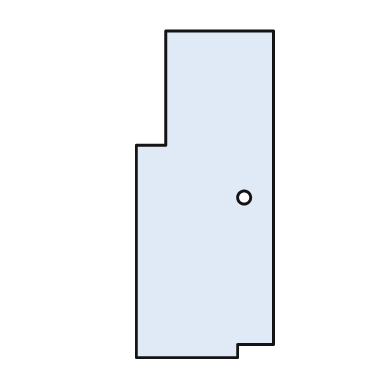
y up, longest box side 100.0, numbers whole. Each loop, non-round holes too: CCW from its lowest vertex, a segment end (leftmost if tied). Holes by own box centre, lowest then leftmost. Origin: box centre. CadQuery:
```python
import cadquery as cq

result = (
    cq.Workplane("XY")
    .moveTo(-21.0, -50.0)
    .lineTo(10.0, -50.0)
    .lineTo(10.0, -46.0)
    .lineTo(21.0, -46.0)
    .lineTo(21.0, 50.0)
    .lineTo(-12.0, 50.0)
    .lineTo(-12.0, 15.0)
    .lineTo(-21.0, 15.0)
    .close()
    .moveTo(12.0, -1.0)
    .circle(2.0)
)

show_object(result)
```